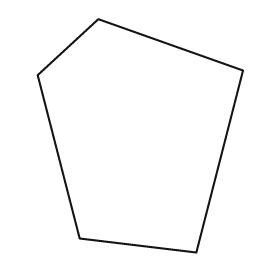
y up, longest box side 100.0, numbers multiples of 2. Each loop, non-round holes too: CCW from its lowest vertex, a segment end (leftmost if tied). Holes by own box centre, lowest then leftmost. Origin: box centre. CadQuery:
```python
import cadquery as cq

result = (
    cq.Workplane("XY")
    .moveTo(24.0, -50.0)
    .lineTo(44.0, 28.0)
    .lineTo(-18.0, 50.0)
    .lineTo(-44.0, 26.0)
    .lineTo(-26.0, -44.0)
    .close()
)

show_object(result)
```